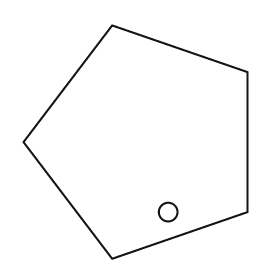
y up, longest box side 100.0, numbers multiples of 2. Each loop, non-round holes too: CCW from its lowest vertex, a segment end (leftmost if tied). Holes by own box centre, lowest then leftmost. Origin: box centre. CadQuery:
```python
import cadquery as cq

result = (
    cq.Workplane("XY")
    .moveTo(-10.0, -50.0)
    .lineTo(48.0, -30.0)
    .lineTo(48.0, 30.0)
    .lineTo(-10.0, 50.0)
    .lineTo(-48.0, 0.0)
    .close()
    .moveTo(14.0, -30.0)
    .circle(4.0)
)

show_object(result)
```